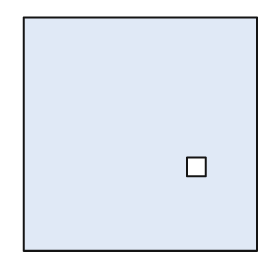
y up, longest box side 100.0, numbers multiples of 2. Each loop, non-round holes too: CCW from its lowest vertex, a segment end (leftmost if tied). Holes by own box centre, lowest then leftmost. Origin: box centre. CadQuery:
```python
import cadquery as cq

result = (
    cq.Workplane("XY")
    .moveTo(-50.0, -50.0)
    .lineTo(50.0, -50.0)
    .lineTo(50.0, 50.0)
    .lineTo(-50.0, 50.0)
    .close()
    .moveTo(20.0, -18.0)
    .lineTo(28.0, -18.0)
    .lineTo(28.0, -10.0)
    .lineTo(20.0, -10.0)
    .close()
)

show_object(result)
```